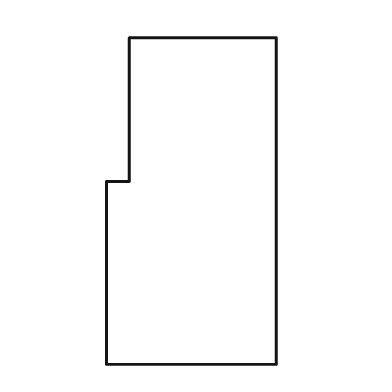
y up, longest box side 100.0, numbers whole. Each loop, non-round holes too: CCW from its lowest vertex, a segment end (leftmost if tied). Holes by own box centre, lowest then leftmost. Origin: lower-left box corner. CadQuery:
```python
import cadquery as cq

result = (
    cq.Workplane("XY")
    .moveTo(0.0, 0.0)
    .lineTo(52.0, 0.0)
    .lineTo(52.0, 100.0)
    .lineTo(7.0, 100.0)
    .lineTo(7.0, 56.0)
    .lineTo(0.0, 56.0)
    .close()
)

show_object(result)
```